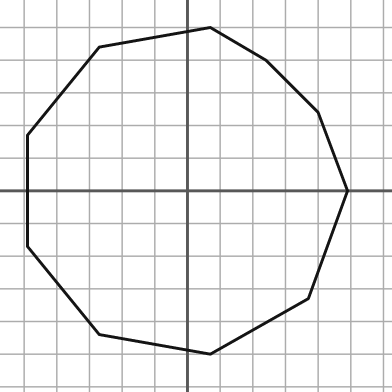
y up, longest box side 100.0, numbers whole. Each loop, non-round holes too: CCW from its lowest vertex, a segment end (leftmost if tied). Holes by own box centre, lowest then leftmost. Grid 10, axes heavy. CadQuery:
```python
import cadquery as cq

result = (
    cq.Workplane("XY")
    .moveTo(7.0, -50.0)
    .lineTo(37.0, -33.0)
    .lineTo(49.0, 0.0)
    .lineTo(40.0, 24.0)
    .lineTo(24.0, 40.0)
    .lineTo(7.0, 50.0)
    .lineTo(-27.0, 44.0)
    .lineTo(-49.0, 17.0)
    .lineTo(-49.0, -17.0)
    .lineTo(-27.0, -44.0)
    .close()
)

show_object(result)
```